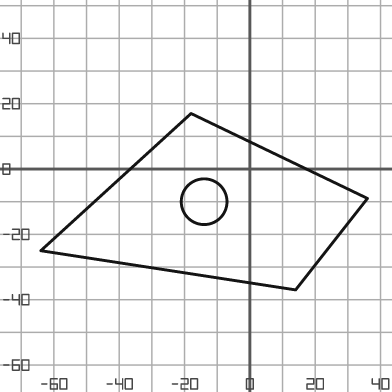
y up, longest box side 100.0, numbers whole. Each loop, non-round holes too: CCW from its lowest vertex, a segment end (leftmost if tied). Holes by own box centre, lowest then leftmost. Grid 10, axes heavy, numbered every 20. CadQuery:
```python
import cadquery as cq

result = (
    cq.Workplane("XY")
    .moveTo(14.0, -37.0)
    .lineTo(36.0, -9.0)
    .lineTo(-18.0, 17.0)
    .lineTo(-64.0, -25.0)
    .close()
    .moveTo(-14.0, -10.0)
    .circle(7.0)
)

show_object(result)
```